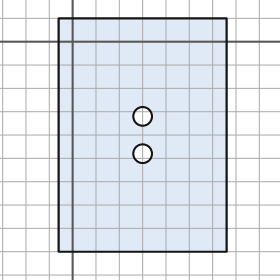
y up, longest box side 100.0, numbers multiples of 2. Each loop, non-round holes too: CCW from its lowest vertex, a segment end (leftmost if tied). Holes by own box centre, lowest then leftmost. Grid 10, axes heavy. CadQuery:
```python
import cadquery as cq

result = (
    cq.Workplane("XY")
    .moveTo(-6.0, -90.0)
    .lineTo(66.0, -90.0)
    .lineTo(66.0, 10.0)
    .lineTo(-6.0, 10.0)
    .close()
    .moveTo(30.0, -48.0)
    .circle(4.0)
    .moveTo(30.0, -32.0)
    .circle(4.0)
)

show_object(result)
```